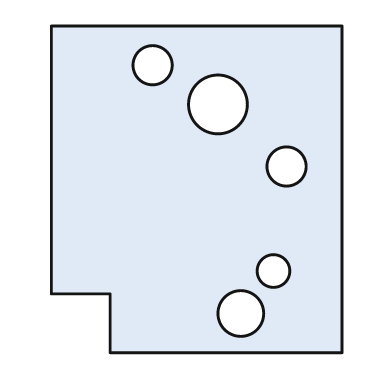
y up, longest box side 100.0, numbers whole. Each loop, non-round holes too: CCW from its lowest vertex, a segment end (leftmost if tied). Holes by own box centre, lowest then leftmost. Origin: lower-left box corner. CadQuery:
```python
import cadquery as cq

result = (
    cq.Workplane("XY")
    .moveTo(18.0, 0.0)
    .lineTo(89.0, 0.0)
    .lineTo(89.0, 100.0)
    .lineTo(0.0, 100.0)
    .lineTo(0.0, 18.0)
    .lineTo(18.0, 18.0)
    .close()
    .moveTo(58.0, 12.0)
    .circle(7.0)
    .moveTo(68.0, 25.0)
    .circle(5.0)
    .moveTo(72.0, 57.0)
    .circle(6.0)
    .moveTo(51.0, 76.0)
    .circle(9.0)
    .moveTo(31.0, 88.0)
    .circle(6.0)
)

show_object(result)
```